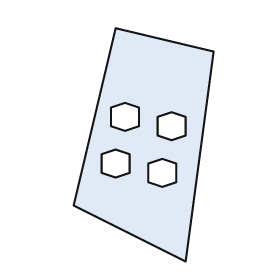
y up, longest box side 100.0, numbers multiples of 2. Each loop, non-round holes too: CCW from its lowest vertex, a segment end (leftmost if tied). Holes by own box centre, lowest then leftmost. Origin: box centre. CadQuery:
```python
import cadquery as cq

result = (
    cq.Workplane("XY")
    .moveTo(18.0, -50.0)
    .lineTo(30.0, 40.0)
    .lineTo(-12.0, 50.0)
    .lineTo(-30.0, -26.0)
    .close()
    .moveTo(8.0, -18.0)
    .lineTo(14.0, -16.0)
    .lineTo(14.0, -8.0)
    .lineTo(8.0, -6.0)
    .lineTo(2.0, -8.0)
    .lineTo(2.0, -16.0)
    .close()
    .moveTo(-12.0, -14.0)
    .lineTo(-6.0, -12.0)
    .lineTo(-6.0, -4.0)
    .lineTo(-12.0, -2.0)
    .lineTo(-18.0, -4.0)
    .lineTo(-18.0, -12.0)
    .close()
    .moveTo(12.0, 2.0)
    .lineTo(18.0, 4.0)
    .lineTo(18.0, 12.0)
    .lineTo(12.0, 14.0)
    .lineTo(6.0, 12.0)
    .lineTo(6.0, 4.0)
    .close()
    .moveTo(-8.0, 6.0)
    .lineTo(-2.0, 8.0)
    .lineTo(-2.0, 16.0)
    .lineTo(-8.0, 18.0)
    .lineTo(-14.0, 16.0)
    .lineTo(-14.0, 8.0)
    .close()
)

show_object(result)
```